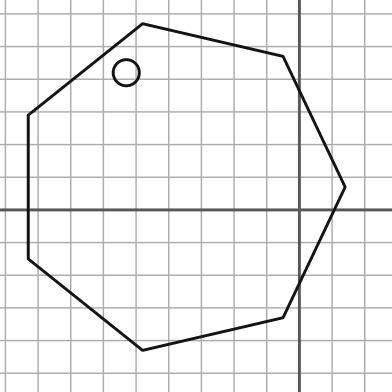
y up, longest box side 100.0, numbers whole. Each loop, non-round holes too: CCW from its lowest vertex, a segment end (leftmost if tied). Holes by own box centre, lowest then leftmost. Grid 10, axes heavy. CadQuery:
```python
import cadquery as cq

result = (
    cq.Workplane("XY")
    .moveTo(-48.0, -43.0)
    .lineTo(-5.0, -33.0)
    .lineTo(14.0, 7.0)
    .lineTo(-5.0, 47.0)
    .lineTo(-48.0, 57.0)
    .lineTo(-83.0, 29.0)
    .lineTo(-83.0, -15.0)
    .close()
    .moveTo(-53.0, 42.0)
    .circle(4.0)
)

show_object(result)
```